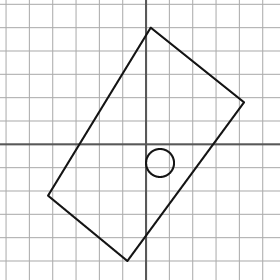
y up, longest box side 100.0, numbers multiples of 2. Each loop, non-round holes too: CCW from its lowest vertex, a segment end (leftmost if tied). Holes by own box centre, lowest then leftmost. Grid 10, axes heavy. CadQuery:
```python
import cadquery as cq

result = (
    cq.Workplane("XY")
    .moveTo(-8.0, -50.0)
    .lineTo(42.0, 18.0)
    .lineTo(2.0, 50.0)
    .lineTo(-42.0, -22.0)
    .close()
    .moveTo(6.0, -8.0)
    .circle(6.0)
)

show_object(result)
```